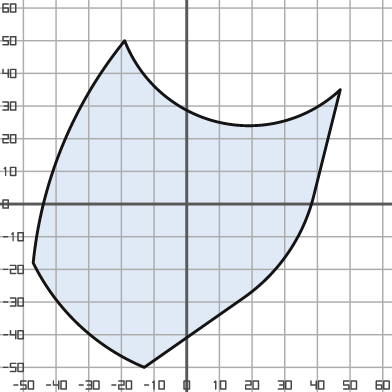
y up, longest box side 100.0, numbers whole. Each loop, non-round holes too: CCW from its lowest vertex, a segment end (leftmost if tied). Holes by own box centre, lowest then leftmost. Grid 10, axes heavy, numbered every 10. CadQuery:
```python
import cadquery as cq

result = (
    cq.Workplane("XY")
    .moveTo(-13.0, -50.0)
    .lineTo(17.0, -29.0)
    .threePointArc((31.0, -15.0), (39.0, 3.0))
    .lineTo(47.0, 35.0)
    .threePointArc((10.0, 25.0), (-19.0, 50.0))
    .threePointArc((-38.0, 18.0), (-47.0, -18.0))
    .threePointArc((-33.0, -37.0), (-13.0, -50.0))
    .close()
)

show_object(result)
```